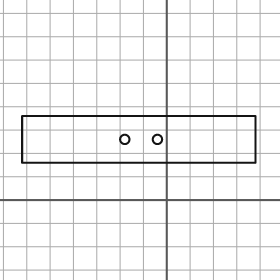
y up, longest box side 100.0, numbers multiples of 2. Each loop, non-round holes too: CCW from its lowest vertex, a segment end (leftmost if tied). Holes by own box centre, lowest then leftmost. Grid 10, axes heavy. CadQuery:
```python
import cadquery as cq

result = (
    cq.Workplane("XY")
    .moveTo(-62.0, 16.0)
    .lineTo(38.0, 16.0)
    .lineTo(38.0, 36.0)
    .lineTo(-62.0, 36.0)
    .close()
    .moveTo(-18.0, 26.0)
    .circle(2.0)
    .moveTo(-4.0, 26.0)
    .circle(2.0)
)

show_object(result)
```